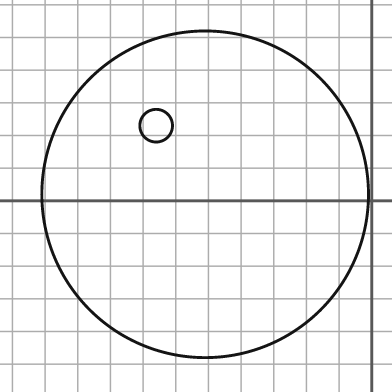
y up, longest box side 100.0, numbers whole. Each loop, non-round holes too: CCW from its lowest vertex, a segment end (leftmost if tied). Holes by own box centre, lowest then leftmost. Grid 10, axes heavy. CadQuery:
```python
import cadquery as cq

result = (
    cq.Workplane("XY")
    .moveTo(-51.0, 2.0)
    .circle(50.0)
    .moveTo(-66.0, 23.0)
    .circle(5.0)
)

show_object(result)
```